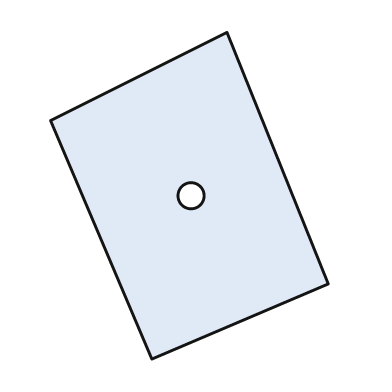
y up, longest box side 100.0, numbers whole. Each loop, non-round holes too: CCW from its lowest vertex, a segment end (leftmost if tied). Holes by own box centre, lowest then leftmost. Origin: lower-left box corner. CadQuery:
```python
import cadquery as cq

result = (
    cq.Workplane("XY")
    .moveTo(31.0, 0.0)
    .lineTo(85.0, 23.0)
    .lineTo(54.0, 100.0)
    .lineTo(0.0, 73.0)
    .close()
    .moveTo(43.0, 50.0)
    .circle(4.0)
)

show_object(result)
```